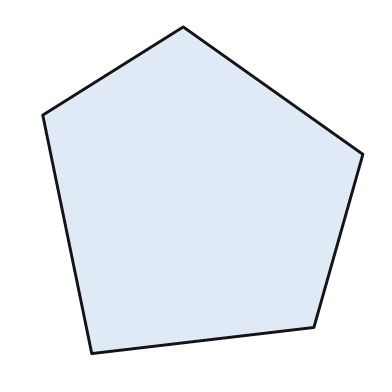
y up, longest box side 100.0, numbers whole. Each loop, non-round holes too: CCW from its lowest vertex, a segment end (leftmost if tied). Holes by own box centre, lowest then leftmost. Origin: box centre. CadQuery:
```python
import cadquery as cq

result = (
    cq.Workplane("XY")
    .moveTo(-34.0, -50.0)
    .lineTo(34.0, -42.0)
    .lineTo(49.0, 11.0)
    .lineTo(-6.0, 50.0)
    .lineTo(-49.0, 23.0)
    .close()
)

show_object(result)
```